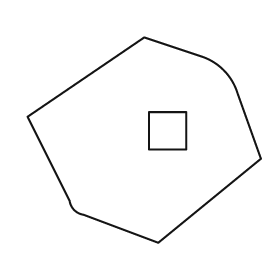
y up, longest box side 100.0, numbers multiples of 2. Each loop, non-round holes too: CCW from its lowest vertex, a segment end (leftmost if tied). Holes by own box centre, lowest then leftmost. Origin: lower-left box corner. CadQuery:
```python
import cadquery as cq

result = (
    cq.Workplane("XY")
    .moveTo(56.0, 0.0)
    .lineTo(100.0, 36.0)
    .lineTo(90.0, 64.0)
    .threePointArc((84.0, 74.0), (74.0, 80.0))
    .lineTo(50.0, 88.0)
    .lineTo(0.0, 54.0)
    .lineTo(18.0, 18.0)
    .threePointArc((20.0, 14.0), (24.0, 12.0))
    .close()
    .moveTo(52.0, 40.0)
    .lineTo(68.0, 40.0)
    .lineTo(68.0, 56.0)
    .lineTo(52.0, 56.0)
    .close()
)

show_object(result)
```